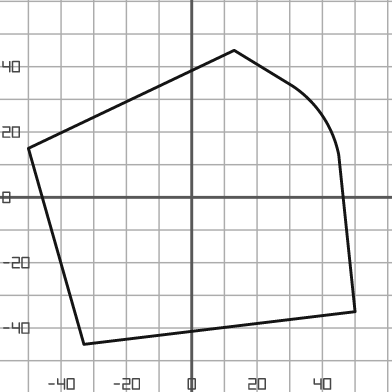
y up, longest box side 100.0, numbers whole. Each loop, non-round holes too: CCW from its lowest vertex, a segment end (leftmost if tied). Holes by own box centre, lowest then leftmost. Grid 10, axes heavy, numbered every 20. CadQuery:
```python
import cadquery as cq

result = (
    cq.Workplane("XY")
    .moveTo(-33.0, -45.0)
    .lineTo(50.0, -35.0)
    .lineTo(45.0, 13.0)
    .threePointArc((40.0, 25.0), (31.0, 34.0))
    .lineTo(13.0, 45.0)
    .lineTo(-50.0, 15.0)
    .close()
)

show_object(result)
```